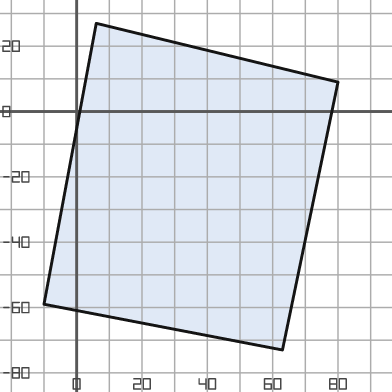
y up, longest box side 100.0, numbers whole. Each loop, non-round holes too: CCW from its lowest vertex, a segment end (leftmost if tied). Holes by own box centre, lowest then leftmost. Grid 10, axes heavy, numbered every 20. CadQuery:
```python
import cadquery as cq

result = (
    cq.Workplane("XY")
    .moveTo(63.0, -73.0)
    .lineTo(80.0, 9.0)
    .lineTo(6.0, 27.0)
    .lineTo(-10.0, -59.0)
    .close()
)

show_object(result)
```